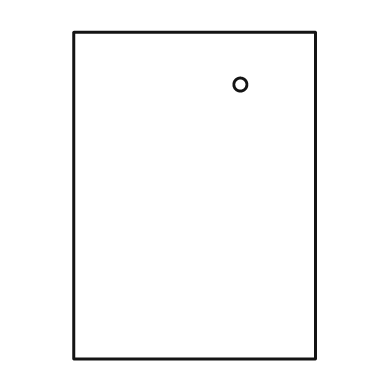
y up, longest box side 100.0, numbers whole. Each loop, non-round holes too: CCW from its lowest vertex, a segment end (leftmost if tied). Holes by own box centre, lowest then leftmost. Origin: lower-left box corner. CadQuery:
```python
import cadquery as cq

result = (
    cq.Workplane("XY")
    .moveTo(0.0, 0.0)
    .lineTo(74.0, 0.0)
    .lineTo(74.0, 100.0)
    .lineTo(0.0, 100.0)
    .close()
    .moveTo(51.0, 84.0)
    .circle(2.0)
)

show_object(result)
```